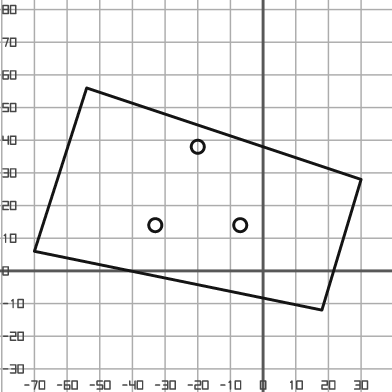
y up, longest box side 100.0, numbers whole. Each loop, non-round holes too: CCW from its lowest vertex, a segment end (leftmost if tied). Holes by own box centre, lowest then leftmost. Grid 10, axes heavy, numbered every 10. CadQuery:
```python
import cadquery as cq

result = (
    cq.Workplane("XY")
    .moveTo(18.0, -12.0)
    .lineTo(30.0, 28.0)
    .lineTo(-54.0, 56.0)
    .lineTo(-70.0, 6.0)
    .close()
    .moveTo(-33.0, 14.0)
    .circle(2.0)
    .moveTo(-7.0, 14.0)
    .circle(2.0)
    .moveTo(-20.0, 38.0)
    .circle(2.0)
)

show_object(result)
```